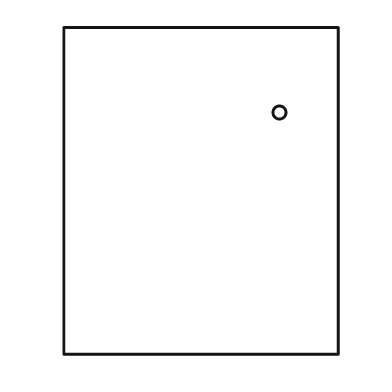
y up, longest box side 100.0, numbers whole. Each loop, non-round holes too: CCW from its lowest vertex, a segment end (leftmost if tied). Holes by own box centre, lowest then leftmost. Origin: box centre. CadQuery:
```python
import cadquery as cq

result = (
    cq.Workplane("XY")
    .moveTo(-42.0, -50.0)
    .lineTo(42.0, -50.0)
    .lineTo(42.0, 50.0)
    .lineTo(-42.0, 50.0)
    .close()
    .moveTo(24.0, 24.0)
    .circle(2.0)
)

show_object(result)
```